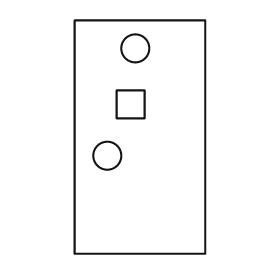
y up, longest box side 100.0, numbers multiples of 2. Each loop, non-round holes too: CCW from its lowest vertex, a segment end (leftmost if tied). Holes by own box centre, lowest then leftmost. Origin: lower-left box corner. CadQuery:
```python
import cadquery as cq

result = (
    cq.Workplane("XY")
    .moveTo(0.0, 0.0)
    .lineTo(56.0, 0.0)
    .lineTo(56.0, 100.0)
    .lineTo(0.0, 100.0)
    .close()
    .moveTo(14.0, 42.0)
    .circle(6.0)
    .moveTo(18.0, 58.0)
    .lineTo(30.0, 58.0)
    .lineTo(30.0, 70.0)
    .lineTo(18.0, 70.0)
    .close()
    .moveTo(26.0, 88.0)
    .circle(6.0)
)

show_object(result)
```